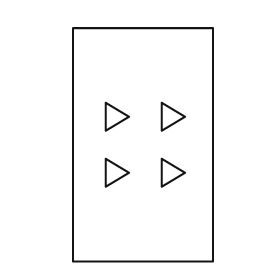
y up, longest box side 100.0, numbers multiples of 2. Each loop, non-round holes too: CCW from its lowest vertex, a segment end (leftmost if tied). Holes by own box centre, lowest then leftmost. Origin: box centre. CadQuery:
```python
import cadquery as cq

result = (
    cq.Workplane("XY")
    .moveTo(-30.0, -50.0)
    .lineTo(30.0, -50.0)
    .lineTo(30.0, 50.0)
    .lineTo(-30.0, 50.0)
    .close()
    .moveTo(-16.0, -18.0)
    .lineTo(-6.0, -12.0)
    .lineTo(-16.0, -6.0)
    .close()
    .moveTo(8.0, -18.0)
    .lineTo(18.0, -12.0)
    .lineTo(8.0, -6.0)
    .close()
    .moveTo(-16.0, 6.0)
    .lineTo(-6.0, 12.0)
    .lineTo(-16.0, 18.0)
    .close()
    .moveTo(8.0, 6.0)
    .lineTo(18.0, 12.0)
    .lineTo(8.0, 18.0)
    .close()
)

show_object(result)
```